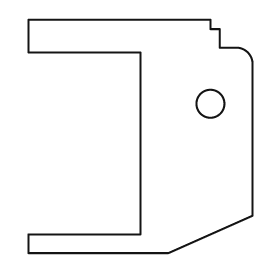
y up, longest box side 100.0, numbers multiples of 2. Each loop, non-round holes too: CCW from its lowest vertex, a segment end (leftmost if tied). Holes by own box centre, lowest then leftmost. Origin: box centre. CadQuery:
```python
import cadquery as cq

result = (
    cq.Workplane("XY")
    .moveTo(-48.0, -50.0)
    .lineTo(12.0, -50.0)
    .lineTo(48.0, -34.0)
    .lineTo(48.0, 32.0)
    .threePointArc((46.0, 36.0), (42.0, 38.0))
    .lineTo(34.0, 38.0)
    .lineTo(34.0, 46.0)
    .lineTo(30.0, 46.0)
    .lineTo(30.0, 50.0)
    .lineTo(-48.0, 50.0)
    .lineTo(-48.0, 36.0)
    .lineTo(0.0, 36.0)
    .lineTo(0.0, -42.0)
    .lineTo(-48.0, -42.0)
    .close()
    .moveTo(30.0, 14.0)
    .circle(6.0)
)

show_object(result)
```